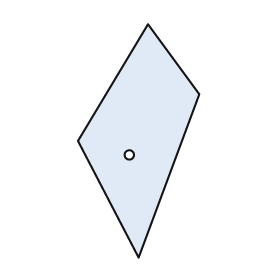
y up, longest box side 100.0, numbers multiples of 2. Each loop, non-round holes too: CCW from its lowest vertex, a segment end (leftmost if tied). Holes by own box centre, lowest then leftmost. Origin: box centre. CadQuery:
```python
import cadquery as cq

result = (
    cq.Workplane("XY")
    .moveTo(0.0, -50.0)
    .lineTo(26.0, 20.0)
    .lineTo(4.0, 50.0)
    .lineTo(-26.0, 0.0)
    .close()
    .moveTo(-4.0, -6.0)
    .circle(2.0)
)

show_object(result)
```